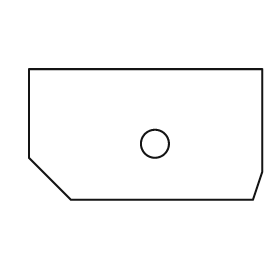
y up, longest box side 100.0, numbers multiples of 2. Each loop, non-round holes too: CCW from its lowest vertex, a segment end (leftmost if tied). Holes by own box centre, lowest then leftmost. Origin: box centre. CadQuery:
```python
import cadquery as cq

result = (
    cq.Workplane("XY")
    .moveTo(-32.0, -28.0)
    .lineTo(46.0, -28.0)
    .lineTo(50.0, -16.0)
    .lineTo(50.0, 28.0)
    .lineTo(-50.0, 28.0)
    .lineTo(-50.0, -10.0)
    .close()
    .moveTo(4.0, -4.0)
    .circle(6.0)
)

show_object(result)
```